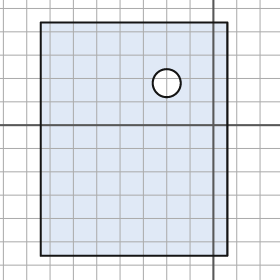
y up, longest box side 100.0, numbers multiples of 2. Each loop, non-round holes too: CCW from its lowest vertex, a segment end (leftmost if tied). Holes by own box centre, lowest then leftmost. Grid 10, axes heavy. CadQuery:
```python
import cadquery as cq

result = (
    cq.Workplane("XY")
    .moveTo(-74.0, -56.0)
    .lineTo(6.0, -56.0)
    .lineTo(6.0, 44.0)
    .lineTo(-74.0, 44.0)
    .close()
    .moveTo(-20.0, 18.0)
    .circle(6.0)
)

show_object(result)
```